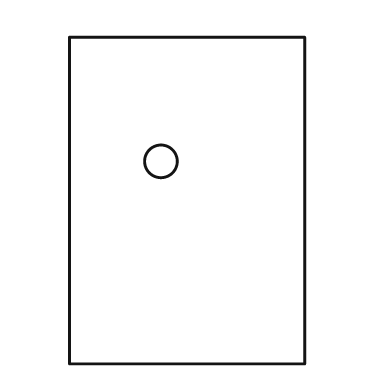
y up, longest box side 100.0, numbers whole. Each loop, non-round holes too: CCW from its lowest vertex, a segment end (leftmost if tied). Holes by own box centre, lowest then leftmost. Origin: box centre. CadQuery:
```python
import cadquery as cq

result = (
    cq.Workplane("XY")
    .moveTo(-36.0, -50.0)
    .lineTo(36.0, -50.0)
    .lineTo(36.0, 50.0)
    .lineTo(-36.0, 50.0)
    .close()
    .moveTo(-8.0, 12.0)
    .circle(5.0)
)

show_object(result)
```